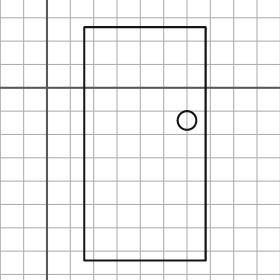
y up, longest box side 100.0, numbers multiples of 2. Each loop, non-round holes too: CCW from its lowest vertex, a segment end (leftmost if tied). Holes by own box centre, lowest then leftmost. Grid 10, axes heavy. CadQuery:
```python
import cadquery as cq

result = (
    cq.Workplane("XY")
    .moveTo(16.0, -74.0)
    .lineTo(68.0, -74.0)
    .lineTo(68.0, 26.0)
    .lineTo(16.0, 26.0)
    .close()
    .moveTo(60.0, -14.0)
    .circle(4.0)
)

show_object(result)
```